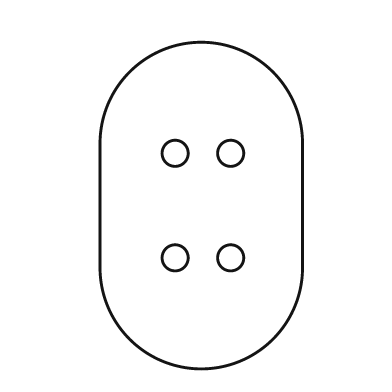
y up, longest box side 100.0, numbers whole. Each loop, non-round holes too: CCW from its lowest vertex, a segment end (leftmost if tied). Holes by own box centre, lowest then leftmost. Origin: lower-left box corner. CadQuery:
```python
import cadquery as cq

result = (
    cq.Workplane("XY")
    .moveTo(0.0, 31.0)
    .threePointArc((31.0, 0.0), (62.0, 31.0))
    .lineTo(62.0, 69.0)
    .threePointArc((31.0, 100.0), (0.0, 69.0))
    .close()
    .moveTo(23.0, 34.0)
    .circle(4.0)
    .moveTo(40.0, 34.0)
    .circle(4.0)
    .moveTo(23.0, 66.0)
    .circle(4.0)
    .moveTo(40.0, 66.0)
    .circle(4.0)
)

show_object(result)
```